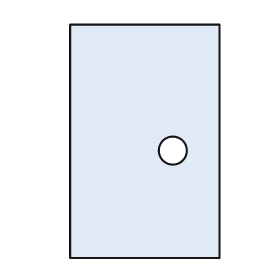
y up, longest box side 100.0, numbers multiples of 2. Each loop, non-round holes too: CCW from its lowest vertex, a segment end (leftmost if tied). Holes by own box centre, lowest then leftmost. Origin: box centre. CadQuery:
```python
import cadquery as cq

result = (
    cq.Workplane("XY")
    .moveTo(-32.0, -50.0)
    .lineTo(32.0, -50.0)
    .lineTo(32.0, 50.0)
    .lineTo(-32.0, 50.0)
    .close()
    .moveTo(12.0, -4.0)
    .circle(6.0)
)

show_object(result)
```